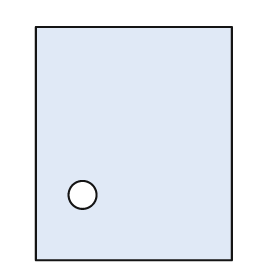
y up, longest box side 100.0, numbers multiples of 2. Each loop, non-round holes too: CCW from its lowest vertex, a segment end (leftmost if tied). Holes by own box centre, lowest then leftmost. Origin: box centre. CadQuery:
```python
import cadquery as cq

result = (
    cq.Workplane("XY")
    .moveTo(-42.0, -50.0)
    .lineTo(42.0, -50.0)
    .lineTo(42.0, 50.0)
    .lineTo(-42.0, 50.0)
    .close()
    .moveTo(-22.0, -22.0)
    .circle(6.0)
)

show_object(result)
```